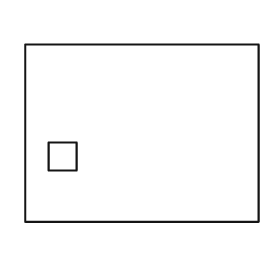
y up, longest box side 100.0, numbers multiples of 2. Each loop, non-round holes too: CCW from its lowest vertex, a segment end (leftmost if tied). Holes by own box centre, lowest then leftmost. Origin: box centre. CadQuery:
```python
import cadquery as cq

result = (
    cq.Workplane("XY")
    .moveTo(-50.0, -38.0)
    .lineTo(50.0, -38.0)
    .lineTo(50.0, 38.0)
    .lineTo(-50.0, 38.0)
    .close()
    .moveTo(-40.0, -16.0)
    .lineTo(-28.0, -16.0)
    .lineTo(-28.0, -4.0)
    .lineTo(-40.0, -4.0)
    .close()
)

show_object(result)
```